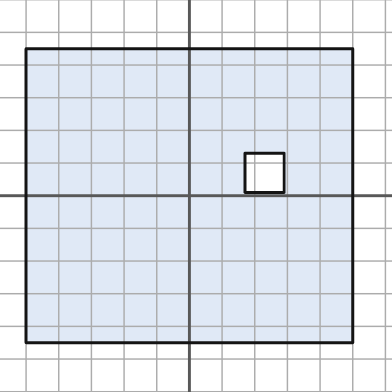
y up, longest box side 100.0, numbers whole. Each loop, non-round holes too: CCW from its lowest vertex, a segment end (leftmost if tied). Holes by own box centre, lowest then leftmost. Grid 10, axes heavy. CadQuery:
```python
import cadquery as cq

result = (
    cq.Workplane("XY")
    .moveTo(-50.0, -45.0)
    .lineTo(50.0, -45.0)
    .lineTo(50.0, 45.0)
    .lineTo(-50.0, 45.0)
    .close()
    .moveTo(17.0, 1.0)
    .lineTo(29.0, 1.0)
    .lineTo(29.0, 13.0)
    .lineTo(17.0, 13.0)
    .close()
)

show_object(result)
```